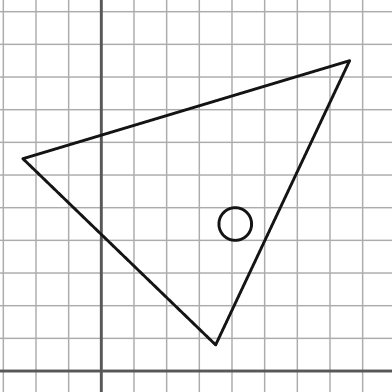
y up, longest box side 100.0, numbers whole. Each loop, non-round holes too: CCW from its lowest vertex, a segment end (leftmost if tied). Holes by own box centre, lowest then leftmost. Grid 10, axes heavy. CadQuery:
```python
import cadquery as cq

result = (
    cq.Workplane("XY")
    .moveTo(35.0, 8.0)
    .lineTo(76.0, 95.0)
    .lineTo(-24.0, 65.0)
    .close()
    .moveTo(41.0, 45.0)
    .circle(5.0)
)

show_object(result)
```